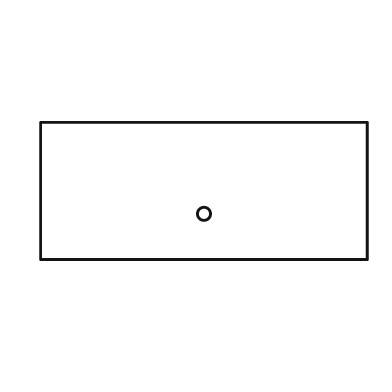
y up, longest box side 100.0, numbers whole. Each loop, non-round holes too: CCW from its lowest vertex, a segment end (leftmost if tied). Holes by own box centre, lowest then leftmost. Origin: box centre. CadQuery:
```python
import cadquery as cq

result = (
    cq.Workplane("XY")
    .moveTo(-50.0, -21.0)
    .lineTo(50.0, -21.0)
    .lineTo(50.0, 21.0)
    .lineTo(-50.0, 21.0)
    .close()
    .moveTo(0.0, -7.0)
    .circle(2.0)
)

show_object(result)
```